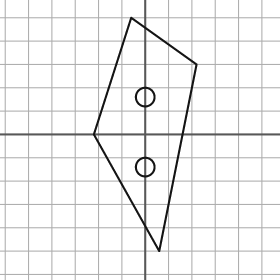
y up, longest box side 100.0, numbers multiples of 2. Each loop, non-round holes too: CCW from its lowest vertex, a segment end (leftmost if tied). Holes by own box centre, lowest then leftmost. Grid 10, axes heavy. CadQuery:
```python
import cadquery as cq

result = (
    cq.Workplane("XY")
    .moveTo(6.0, -50.0)
    .lineTo(22.0, 30.0)
    .lineTo(-6.0, 50.0)
    .lineTo(-22.0, 0.0)
    .close()
    .moveTo(0.0, -14.0)
    .circle(4.0)
    .moveTo(0.0, 16.0)
    .circle(4.0)
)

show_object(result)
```